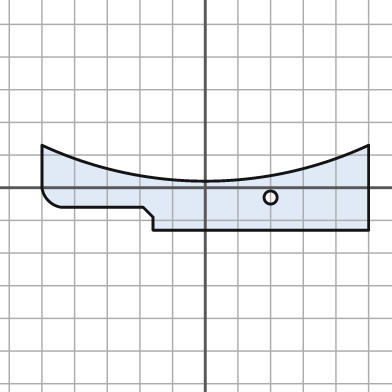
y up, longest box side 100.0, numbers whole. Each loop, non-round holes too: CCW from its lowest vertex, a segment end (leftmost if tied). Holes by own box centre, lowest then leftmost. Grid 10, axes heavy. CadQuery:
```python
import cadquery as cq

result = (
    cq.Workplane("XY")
    .moveTo(-16.0, -13.0)
    .lineTo(50.0, -13.0)
    .lineTo(50.0, 13.0)
    .threePointArc((0.0, 2.0), (-50.0, 13.0))
    .lineTo(-50.0, 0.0)
    .threePointArc((-48.0, -4.0), (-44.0, -6.0))
    .lineTo(-19.0, -6.0)
    .lineTo(-16.0, -9.0)
    .close()
    .moveTo(20.0, -3.0)
    .circle(2.0)
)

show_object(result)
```